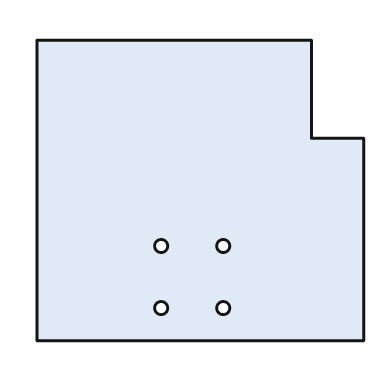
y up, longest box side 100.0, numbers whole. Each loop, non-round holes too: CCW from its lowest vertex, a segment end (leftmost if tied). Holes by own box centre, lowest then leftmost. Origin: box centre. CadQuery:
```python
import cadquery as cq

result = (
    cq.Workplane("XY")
    .moveTo(-50.0, -46.0)
    .lineTo(50.0, -46.0)
    .lineTo(50.0, 16.0)
    .lineTo(34.0, 16.0)
    .lineTo(34.0, 46.0)
    .lineTo(-50.0, 46.0)
    .close()
    .moveTo(-12.0, -36.0)
    .circle(2.0)
    .moveTo(7.0, -36.0)
    .circle(2.0)
    .moveTo(-12.0, -17.0)
    .circle(2.0)
    .moveTo(7.0, -17.0)
    .circle(2.0)
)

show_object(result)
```